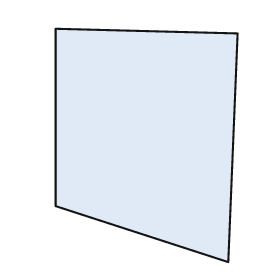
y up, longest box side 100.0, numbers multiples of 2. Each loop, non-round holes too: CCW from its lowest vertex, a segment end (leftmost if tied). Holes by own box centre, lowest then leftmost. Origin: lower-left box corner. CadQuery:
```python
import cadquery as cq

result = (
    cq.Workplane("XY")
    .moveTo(74.0, 0.0)
    .lineTo(78.0, 98.0)
    .lineTo(0.0, 100.0)
    .lineTo(0.0, 24.0)
    .close()
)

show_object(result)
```